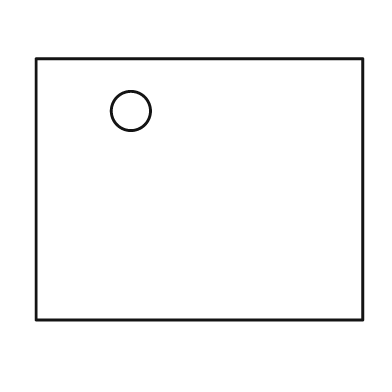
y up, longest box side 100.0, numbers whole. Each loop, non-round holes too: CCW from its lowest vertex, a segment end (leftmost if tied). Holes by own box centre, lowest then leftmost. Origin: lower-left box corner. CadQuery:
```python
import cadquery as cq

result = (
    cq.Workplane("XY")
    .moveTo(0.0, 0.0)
    .lineTo(100.0, 0.0)
    .lineTo(100.0, 80.0)
    .lineTo(0.0, 80.0)
    .close()
    .moveTo(29.0, 64.0)
    .circle(6.0)
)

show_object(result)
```